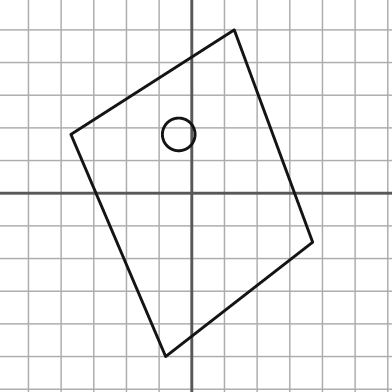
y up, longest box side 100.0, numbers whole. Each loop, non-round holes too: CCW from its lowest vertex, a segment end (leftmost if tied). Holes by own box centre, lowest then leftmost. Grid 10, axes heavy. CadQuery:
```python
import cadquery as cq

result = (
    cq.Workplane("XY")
    .moveTo(-8.0, -50.0)
    .lineTo(37.0, -15.0)
    .lineTo(13.0, 50.0)
    .lineTo(-37.0, 18.0)
    .close()
    .moveTo(-4.0, 18.0)
    .circle(5.0)
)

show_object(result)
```